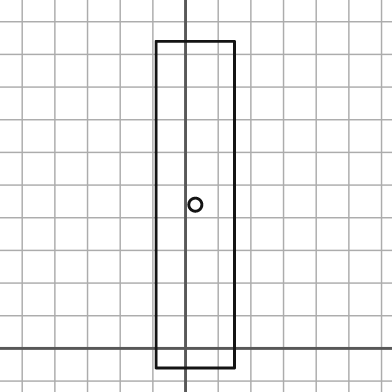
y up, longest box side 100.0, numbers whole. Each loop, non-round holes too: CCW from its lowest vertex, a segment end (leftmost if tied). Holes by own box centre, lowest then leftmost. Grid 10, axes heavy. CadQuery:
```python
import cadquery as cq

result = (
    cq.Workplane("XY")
    .moveTo(-9.0, -6.0)
    .lineTo(15.0, -6.0)
    .lineTo(15.0, 94.0)
    .lineTo(-9.0, 94.0)
    .close()
    .moveTo(3.0, 44.0)
    .circle(2.0)
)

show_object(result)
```